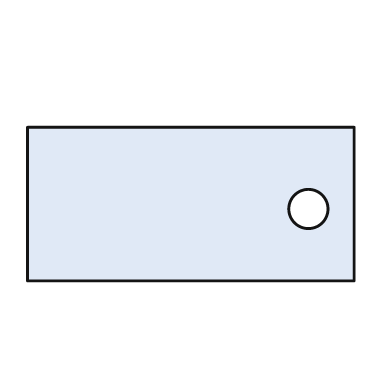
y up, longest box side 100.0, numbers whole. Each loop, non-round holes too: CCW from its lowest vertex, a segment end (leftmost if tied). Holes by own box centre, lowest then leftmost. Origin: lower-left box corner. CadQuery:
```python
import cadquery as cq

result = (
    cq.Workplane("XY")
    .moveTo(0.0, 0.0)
    .lineTo(100.0, 0.0)
    .lineTo(100.0, 47.0)
    .lineTo(0.0, 47.0)
    .close()
    .moveTo(86.0, 22.0)
    .circle(6.0)
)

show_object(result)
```